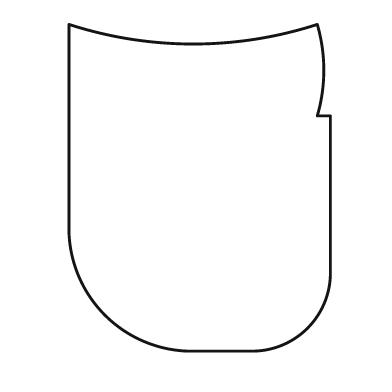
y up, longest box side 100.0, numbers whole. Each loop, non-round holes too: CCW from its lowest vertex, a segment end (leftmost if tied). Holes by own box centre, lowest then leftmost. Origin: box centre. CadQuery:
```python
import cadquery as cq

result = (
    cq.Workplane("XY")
    .moveTo(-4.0, -50.0)
    .lineTo(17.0, -50.0)
    .threePointArc((33.0, -43.0), (40.0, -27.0))
    .lineTo(40.0, 22.0)
    .lineTo(36.0, 22.0)
    .threePointArc((38.0, 36.0), (36.0, 50.0))
    .threePointArc((-2.0, 44.0), (-40.0, 50.0))
    .lineTo(-40.0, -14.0)
    .threePointArc((-29.0, -39.0), (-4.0, -50.0))
    .close()
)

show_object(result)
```